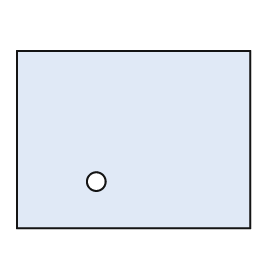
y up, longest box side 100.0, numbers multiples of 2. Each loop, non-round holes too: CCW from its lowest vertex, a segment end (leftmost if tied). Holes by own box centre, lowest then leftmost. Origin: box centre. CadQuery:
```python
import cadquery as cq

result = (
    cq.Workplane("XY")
    .moveTo(-50.0, -38.0)
    .lineTo(50.0, -38.0)
    .lineTo(50.0, 38.0)
    .lineTo(-50.0, 38.0)
    .close()
    .moveTo(-16.0, -18.0)
    .circle(4.0)
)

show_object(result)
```